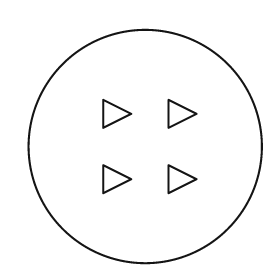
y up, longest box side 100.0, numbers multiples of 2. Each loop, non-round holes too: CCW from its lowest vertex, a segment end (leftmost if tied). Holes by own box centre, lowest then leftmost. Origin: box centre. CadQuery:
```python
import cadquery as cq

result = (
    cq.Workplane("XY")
    .moveTo(0.0, 0.0)
    .circle(50.0)
    .moveTo(-18.0, -20.0)
    .lineTo(-6.0, -14.0)
    .lineTo(-18.0, -8.0)
    .close()
    .moveTo(10.0, -20.0)
    .lineTo(22.0, -14.0)
    .lineTo(10.0, -8.0)
    .close()
    .moveTo(-18.0, 8.0)
    .lineTo(-6.0, 14.0)
    .lineTo(-18.0, 20.0)
    .close()
    .moveTo(10.0, 8.0)
    .lineTo(22.0, 14.0)
    .lineTo(10.0, 20.0)
    .close()
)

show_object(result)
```